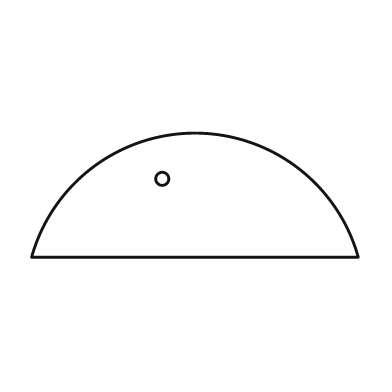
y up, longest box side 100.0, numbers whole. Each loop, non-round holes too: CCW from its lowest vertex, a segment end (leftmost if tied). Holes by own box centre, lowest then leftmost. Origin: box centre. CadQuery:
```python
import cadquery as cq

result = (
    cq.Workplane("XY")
    .moveTo(-50.0, -19.0)
    .lineTo(50.0, -19.0)
    .threePointArc((0.0, 19.0), (-50.0, -19.0))
    .close()
    .moveTo(-10.0, 5.0)
    .circle(2.0)
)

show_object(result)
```